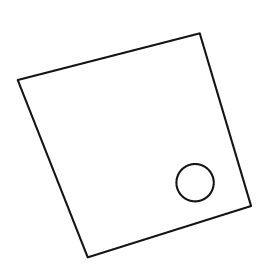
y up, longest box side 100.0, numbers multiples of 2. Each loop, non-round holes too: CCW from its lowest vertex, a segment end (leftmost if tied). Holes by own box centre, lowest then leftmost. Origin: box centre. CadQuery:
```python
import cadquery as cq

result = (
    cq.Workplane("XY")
    .moveTo(-20.0, -48.0)
    .lineTo(50.0, -26.0)
    .lineTo(28.0, 48.0)
    .lineTo(-50.0, 28.0)
    .close()
    .moveTo(26.0, -16.0)
    .circle(8.0)
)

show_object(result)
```